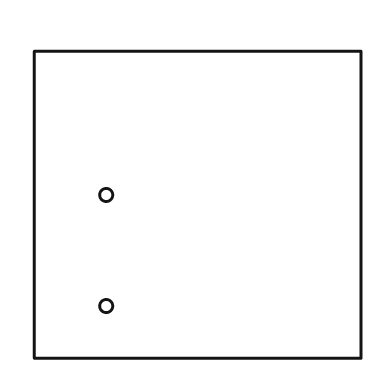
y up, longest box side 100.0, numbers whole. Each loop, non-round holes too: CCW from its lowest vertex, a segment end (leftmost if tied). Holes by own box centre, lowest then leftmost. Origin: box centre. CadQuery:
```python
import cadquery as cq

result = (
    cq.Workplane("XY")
    .moveTo(-50.0, -47.0)
    .lineTo(50.0, -47.0)
    .lineTo(50.0, 47.0)
    .lineTo(-50.0, 47.0)
    .close()
    .moveTo(-28.0, -31.0)
    .circle(2.0)
    .moveTo(-28.0, 3.0)
    .circle(2.0)
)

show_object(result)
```